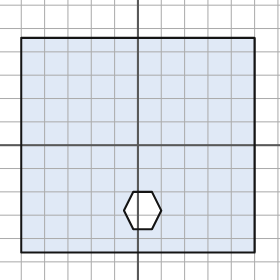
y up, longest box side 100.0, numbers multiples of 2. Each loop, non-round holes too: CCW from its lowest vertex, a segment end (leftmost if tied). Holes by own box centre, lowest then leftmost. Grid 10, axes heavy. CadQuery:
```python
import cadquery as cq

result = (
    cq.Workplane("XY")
    .moveTo(-50.0, -46.0)
    .lineTo(50.0, -46.0)
    .lineTo(50.0, 46.0)
    .lineTo(-50.0, 46.0)
    .close()
    .moveTo(-2.0, -36.0)
    .lineTo(6.0, -36.0)
    .lineTo(10.0, -28.0)
    .lineTo(6.0, -20.0)
    .lineTo(-2.0, -20.0)
    .lineTo(-6.0, -28.0)
    .close()
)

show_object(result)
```